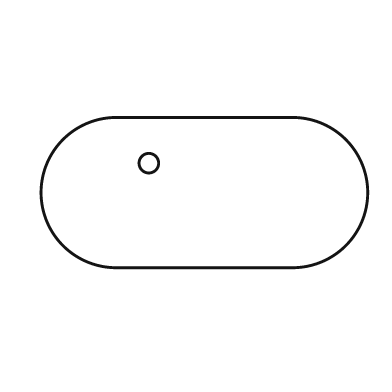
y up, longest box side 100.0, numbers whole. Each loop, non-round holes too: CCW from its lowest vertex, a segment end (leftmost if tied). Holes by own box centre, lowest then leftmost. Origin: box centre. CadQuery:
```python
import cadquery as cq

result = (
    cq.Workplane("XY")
    .moveTo(-27.0, -23.0)
    .lineTo(27.0, -23.0)
    .threePointArc((50.0, 0.0), (27.0, 23.0))
    .lineTo(-27.0, 23.0)
    .threePointArc((-50.0, 0.0), (-27.0, -23.0))
    .close()
    .moveTo(-17.0, 9.0)
    .circle(3.0)
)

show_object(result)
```